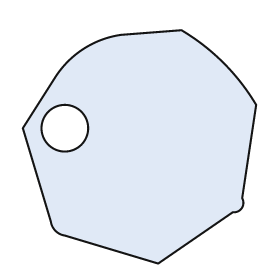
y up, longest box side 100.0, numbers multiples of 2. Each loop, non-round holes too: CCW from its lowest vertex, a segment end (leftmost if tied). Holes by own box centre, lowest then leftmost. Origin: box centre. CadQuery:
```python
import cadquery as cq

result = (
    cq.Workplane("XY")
    .moveTo(8.0, -50.0)
    .lineTo(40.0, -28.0)
    .threePointArc((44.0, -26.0), (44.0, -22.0))
    .lineTo(50.0, 18.0)
    .threePointArc((36.0, 36.0), (18.0, 50.0))
    .lineTo(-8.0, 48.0)
    .threePointArc((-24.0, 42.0), (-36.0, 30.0))
    .lineTo(-50.0, 8.0)
    .lineTo(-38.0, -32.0)
    .threePointArc((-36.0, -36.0), (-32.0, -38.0))
    .close()
    .moveTo(-32.0, 8.0)
    .circle(10.0)
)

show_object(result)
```